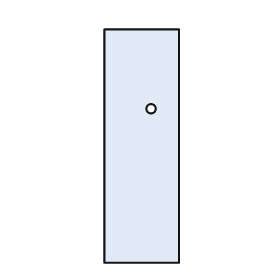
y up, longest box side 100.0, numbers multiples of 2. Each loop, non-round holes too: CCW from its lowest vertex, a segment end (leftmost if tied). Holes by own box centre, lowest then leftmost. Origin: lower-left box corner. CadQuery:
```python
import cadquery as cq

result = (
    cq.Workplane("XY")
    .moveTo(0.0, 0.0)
    .lineTo(32.0, 0.0)
    .lineTo(32.0, 100.0)
    .lineTo(0.0, 100.0)
    .close()
    .moveTo(20.0, 66.0)
    .circle(2.0)
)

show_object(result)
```